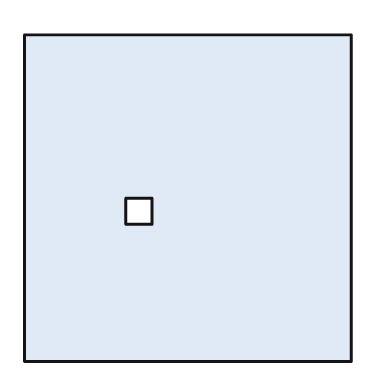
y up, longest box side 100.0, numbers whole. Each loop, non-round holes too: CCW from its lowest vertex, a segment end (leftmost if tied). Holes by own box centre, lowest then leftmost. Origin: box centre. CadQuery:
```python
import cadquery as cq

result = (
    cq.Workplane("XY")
    .moveTo(-50.0, -50.0)
    .lineTo(50.0, -50.0)
    .lineTo(50.0, 50.0)
    .lineTo(-50.0, 50.0)
    .close()
    .moveTo(-19.0, -8.0)
    .lineTo(-11.0, -8.0)
    .lineTo(-11.0, 0.0)
    .lineTo(-19.0, 0.0)
    .close()
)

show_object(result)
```